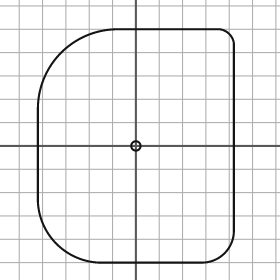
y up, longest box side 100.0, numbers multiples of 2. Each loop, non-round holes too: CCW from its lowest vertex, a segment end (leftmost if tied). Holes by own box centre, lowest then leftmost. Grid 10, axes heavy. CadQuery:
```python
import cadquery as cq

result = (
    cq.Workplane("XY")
    .moveTo(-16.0, -50.0)
    .lineTo(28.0, -50.0)
    .threePointArc((38.0, -46.0), (42.0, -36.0))
    .lineTo(42.0, 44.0)
    .threePointArc((40.0, 48.0), (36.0, 50.0))
    .lineTo(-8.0, 50.0)
    .threePointArc((-32.0, 40.0), (-42.0, 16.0))
    .lineTo(-42.0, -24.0)
    .threePointArc((-34.0, -42.0), (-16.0, -50.0))
    .close()
    .moveTo(0.0, 0.0)
    .circle(2.0)
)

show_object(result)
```